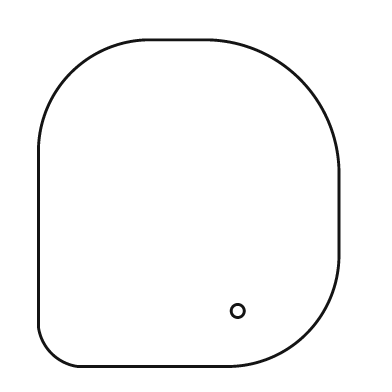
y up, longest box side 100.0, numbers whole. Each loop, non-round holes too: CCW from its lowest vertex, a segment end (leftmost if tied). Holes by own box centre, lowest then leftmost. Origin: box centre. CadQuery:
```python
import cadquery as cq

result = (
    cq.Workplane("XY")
    .moveTo(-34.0, -50.0)
    .lineTo(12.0, -50.0)
    .threePointArc((36.0, -40.0), (46.0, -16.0))
    .lineTo(46.0, 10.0)
    .threePointArc((34.0, 38.0), (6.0, 50.0))
    .lineTo(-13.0, 50.0)
    .threePointArc((-36.0, 40.0), (-46.0, 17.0))
    .lineTo(-46.0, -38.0)
    .threePointArc((-42.0, -46.0), (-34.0, -50.0))
    .close()
    .moveTo(15.0, -33.0)
    .circle(2.0)
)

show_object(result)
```